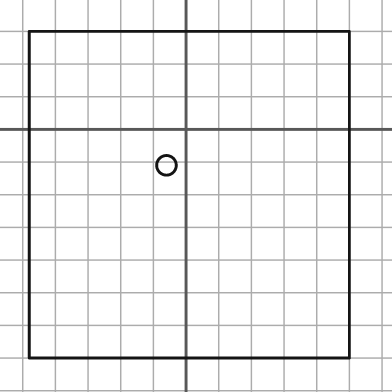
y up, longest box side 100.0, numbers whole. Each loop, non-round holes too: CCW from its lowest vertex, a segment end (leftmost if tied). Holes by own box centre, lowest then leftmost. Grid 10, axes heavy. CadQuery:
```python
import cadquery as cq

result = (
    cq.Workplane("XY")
    .moveTo(-48.0, -70.0)
    .lineTo(50.0, -70.0)
    .lineTo(50.0, 30.0)
    .lineTo(-48.0, 30.0)
    .close()
    .moveTo(-6.0, -11.0)
    .circle(3.0)
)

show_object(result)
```